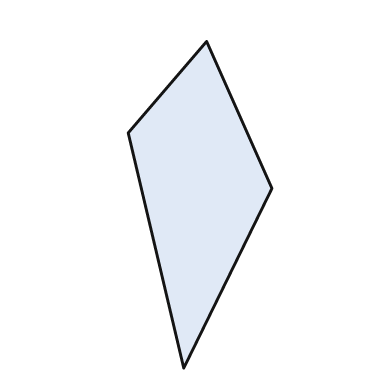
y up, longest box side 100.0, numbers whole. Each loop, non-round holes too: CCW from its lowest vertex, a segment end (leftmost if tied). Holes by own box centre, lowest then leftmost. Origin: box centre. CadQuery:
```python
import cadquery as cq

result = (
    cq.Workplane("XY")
    .moveTo(-5.0, -50.0)
    .lineTo(22.0, 5.0)
    .lineTo(2.0, 50.0)
    .lineTo(-22.0, 22.0)
    .close()
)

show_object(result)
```